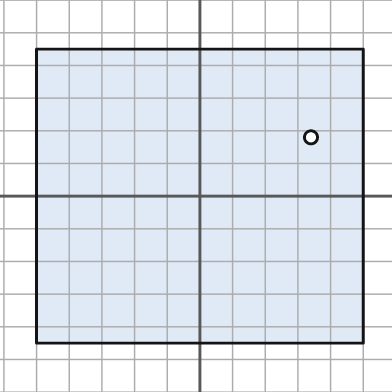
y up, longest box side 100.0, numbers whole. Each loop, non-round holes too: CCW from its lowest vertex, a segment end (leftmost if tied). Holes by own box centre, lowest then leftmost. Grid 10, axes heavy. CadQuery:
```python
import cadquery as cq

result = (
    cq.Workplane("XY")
    .moveTo(-50.0, -45.0)
    .lineTo(50.0, -45.0)
    .lineTo(50.0, 45.0)
    .lineTo(-50.0, 45.0)
    .close()
    .moveTo(34.0, 18.0)
    .circle(2.0)
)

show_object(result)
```